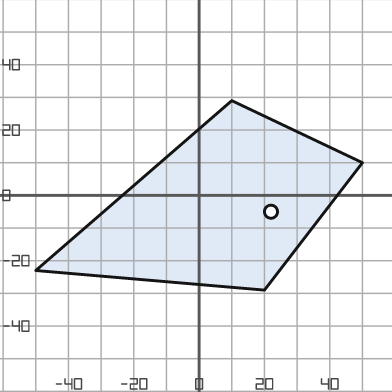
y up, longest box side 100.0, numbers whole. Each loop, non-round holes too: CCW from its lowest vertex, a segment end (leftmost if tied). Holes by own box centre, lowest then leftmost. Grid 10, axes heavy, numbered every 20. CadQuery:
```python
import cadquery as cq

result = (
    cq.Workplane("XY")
    .moveTo(20.0, -29.0)
    .lineTo(50.0, 10.0)
    .lineTo(10.0, 29.0)
    .lineTo(-50.0, -23.0)
    .close()
    .moveTo(22.0, -5.0)
    .circle(2.0)
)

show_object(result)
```